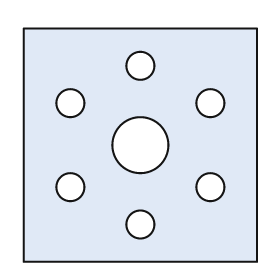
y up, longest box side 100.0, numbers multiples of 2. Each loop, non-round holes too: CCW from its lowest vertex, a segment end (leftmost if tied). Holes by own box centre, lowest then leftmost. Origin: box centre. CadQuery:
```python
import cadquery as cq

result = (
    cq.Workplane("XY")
    .moveTo(-50.0, -50.0)
    .lineTo(50.0, -50.0)
    .lineTo(50.0, 50.0)
    .lineTo(-50.0, 50.0)
    .close()
    .moveTo(0.0, -34.0)
    .circle(6.0)
    .moveTo(-30.0, -18.0)
    .circle(6.0)
    .moveTo(30.0, -18.0)
    .circle(6.0)
    .moveTo(0.0, 0.0)
    .circle(12.0)
    .moveTo(-30.0, 18.0)
    .circle(6.0)
    .moveTo(30.0, 18.0)
    .circle(6.0)
    .moveTo(0.0, 34.0)
    .circle(6.0)
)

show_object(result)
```